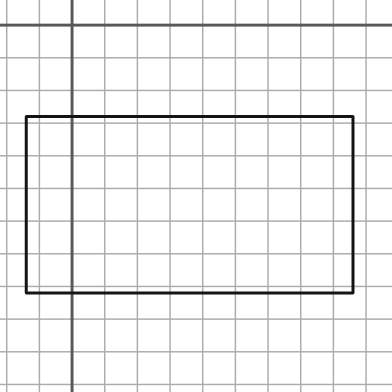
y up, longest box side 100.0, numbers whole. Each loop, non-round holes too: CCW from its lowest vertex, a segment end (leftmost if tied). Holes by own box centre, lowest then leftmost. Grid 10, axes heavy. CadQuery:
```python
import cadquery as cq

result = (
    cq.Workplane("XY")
    .moveTo(-14.0, -82.0)
    .lineTo(86.0, -82.0)
    .lineTo(86.0, -28.0)
    .lineTo(-14.0, -28.0)
    .close()
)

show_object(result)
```